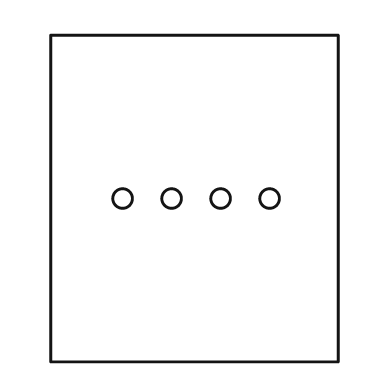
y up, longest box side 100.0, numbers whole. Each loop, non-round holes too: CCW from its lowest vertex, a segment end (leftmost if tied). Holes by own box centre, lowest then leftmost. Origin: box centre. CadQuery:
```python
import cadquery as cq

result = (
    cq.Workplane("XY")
    .moveTo(-44.0, -50.0)
    .lineTo(44.0, -50.0)
    .lineTo(44.0, 50.0)
    .lineTo(-44.0, 50.0)
    .close()
    .moveTo(-22.0, 0.0)
    .circle(3.0)
    .moveTo(-7.0, 0.0)
    .circle(3.0)
    .moveTo(8.0, 0.0)
    .circle(3.0)
    .moveTo(23.0, 0.0)
    .circle(3.0)
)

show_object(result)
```